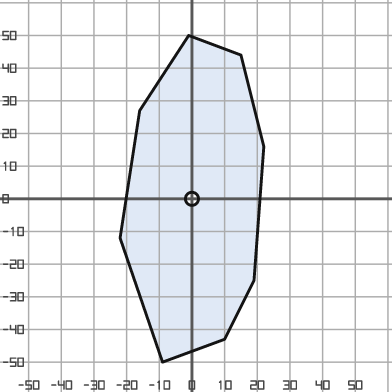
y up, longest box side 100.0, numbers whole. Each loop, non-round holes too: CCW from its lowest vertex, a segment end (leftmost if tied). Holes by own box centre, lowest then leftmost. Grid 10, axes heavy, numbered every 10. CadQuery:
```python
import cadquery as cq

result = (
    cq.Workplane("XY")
    .moveTo(-9.0, -50.0)
    .lineTo(10.0, -43.0)
    .lineTo(19.0, -25.0)
    .lineTo(22.0, 16.0)
    .lineTo(15.0, 44.0)
    .lineTo(-1.0, 50.0)
    .lineTo(-16.0, 27.0)
    .lineTo(-22.0, -12.0)
    .close()
    .moveTo(0.0, 0.0)
    .circle(2.0)
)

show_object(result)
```